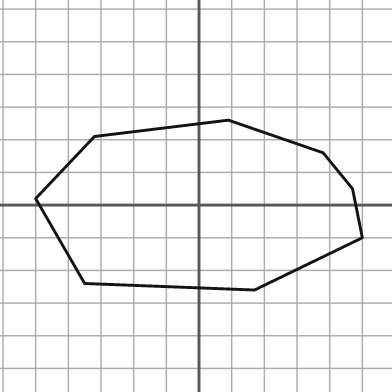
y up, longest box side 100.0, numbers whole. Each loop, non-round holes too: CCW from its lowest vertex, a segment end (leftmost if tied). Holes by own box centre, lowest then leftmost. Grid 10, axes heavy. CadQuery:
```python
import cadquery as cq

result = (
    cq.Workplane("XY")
    .moveTo(17.0, -26.0)
    .lineTo(50.0, -10.0)
    .lineTo(47.0, 5.0)
    .lineTo(38.0, 16.0)
    .lineTo(9.0, 26.0)
    .lineTo(-32.0, 21.0)
    .lineTo(-50.0, 2.0)
    .lineTo(-35.0, -24.0)
    .close()
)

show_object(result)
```